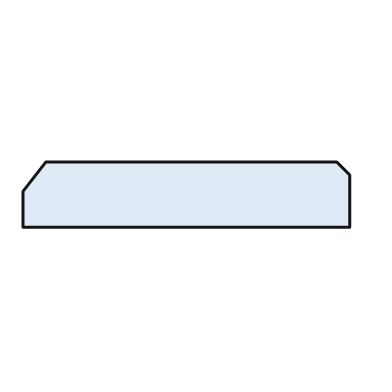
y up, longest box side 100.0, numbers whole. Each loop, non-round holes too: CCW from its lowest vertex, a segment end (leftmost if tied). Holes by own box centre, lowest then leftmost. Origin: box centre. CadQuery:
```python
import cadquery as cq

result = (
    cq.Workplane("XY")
    .moveTo(-50.0, -10.0)
    .lineTo(50.0, -10.0)
    .lineTo(50.0, 6.0)
    .lineTo(46.0, 10.0)
    .lineTo(-43.0, 10.0)
    .lineTo(-50.0, 1.0)
    .close()
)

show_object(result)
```